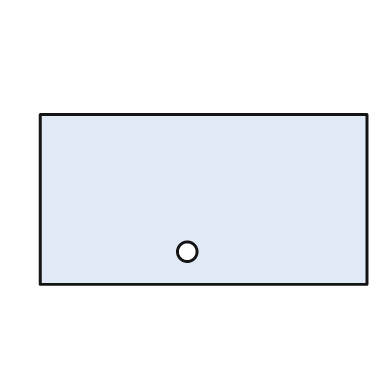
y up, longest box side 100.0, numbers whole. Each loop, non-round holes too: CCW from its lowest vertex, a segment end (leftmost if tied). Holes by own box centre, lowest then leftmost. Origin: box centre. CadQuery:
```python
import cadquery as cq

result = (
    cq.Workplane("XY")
    .moveTo(-50.0, -26.0)
    .lineTo(50.0, -26.0)
    .lineTo(50.0, 26.0)
    .lineTo(-50.0, 26.0)
    .close()
    .moveTo(-5.0, -16.0)
    .circle(3.0)
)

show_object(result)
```